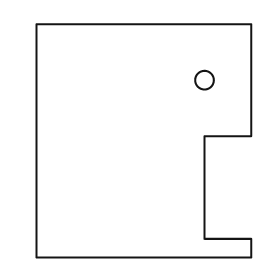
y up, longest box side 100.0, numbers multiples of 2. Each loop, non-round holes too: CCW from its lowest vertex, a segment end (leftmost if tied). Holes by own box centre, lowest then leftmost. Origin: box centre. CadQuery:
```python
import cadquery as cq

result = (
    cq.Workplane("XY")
    .moveTo(-46.0, -50.0)
    .lineTo(46.0, -50.0)
    .lineTo(46.0, -42.0)
    .lineTo(26.0, -42.0)
    .lineTo(26.0, 2.0)
    .lineTo(46.0, 2.0)
    .lineTo(46.0, 50.0)
    .lineTo(-46.0, 50.0)
    .close()
    .moveTo(26.0, 26.0)
    .circle(4.0)
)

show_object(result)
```